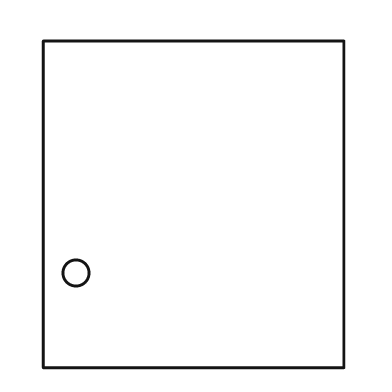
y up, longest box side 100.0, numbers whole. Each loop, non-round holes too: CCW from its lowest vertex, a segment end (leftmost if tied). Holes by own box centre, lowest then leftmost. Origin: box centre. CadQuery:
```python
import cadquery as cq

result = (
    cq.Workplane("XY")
    .moveTo(-46.0, -50.0)
    .lineTo(46.0, -50.0)
    .lineTo(46.0, 50.0)
    .lineTo(-46.0, 50.0)
    .close()
    .moveTo(-36.0, -21.0)
    .circle(4.0)
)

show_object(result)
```